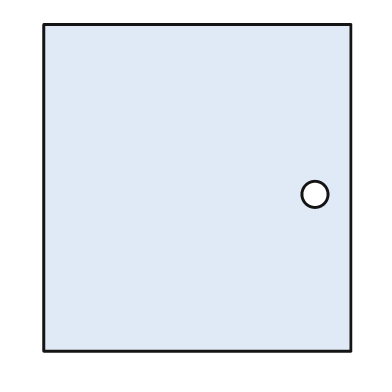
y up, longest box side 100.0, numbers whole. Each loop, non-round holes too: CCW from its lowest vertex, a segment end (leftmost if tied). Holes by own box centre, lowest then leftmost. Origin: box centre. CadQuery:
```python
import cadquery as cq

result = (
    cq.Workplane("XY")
    .moveTo(-47.0, -50.0)
    .lineTo(47.0, -50.0)
    .lineTo(47.0, 50.0)
    .lineTo(-47.0, 50.0)
    .close()
    .moveTo(36.0, -2.0)
    .circle(4.0)
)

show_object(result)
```